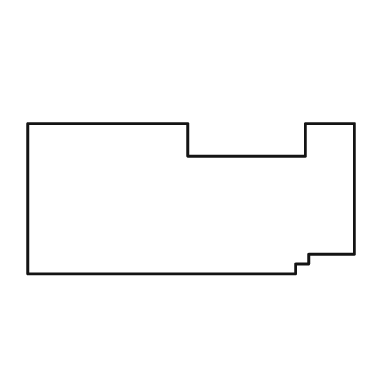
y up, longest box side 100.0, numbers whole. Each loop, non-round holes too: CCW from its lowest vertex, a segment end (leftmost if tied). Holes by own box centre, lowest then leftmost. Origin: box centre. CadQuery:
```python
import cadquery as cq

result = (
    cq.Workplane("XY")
    .moveTo(-50.0, -23.0)
    .lineTo(32.0, -23.0)
    .lineTo(32.0, -20.0)
    .lineTo(36.0, -20.0)
    .lineTo(36.0, -17.0)
    .lineTo(50.0, -17.0)
    .lineTo(50.0, 23.0)
    .lineTo(35.0, 23.0)
    .lineTo(35.0, 13.0)
    .lineTo(-1.0, 13.0)
    .lineTo(-1.0, 23.0)
    .lineTo(-50.0, 23.0)
    .close()
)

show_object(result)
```